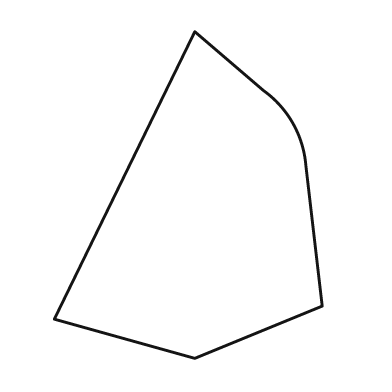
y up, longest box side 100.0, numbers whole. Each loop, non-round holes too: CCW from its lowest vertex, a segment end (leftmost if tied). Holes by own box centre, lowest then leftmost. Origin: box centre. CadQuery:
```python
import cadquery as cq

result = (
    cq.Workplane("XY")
    .moveTo(2.0, -50.0)
    .lineTo(41.0, -34.0)
    .lineTo(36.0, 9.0)
    .threePointArc((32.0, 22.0), (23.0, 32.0))
    .lineTo(2.0, 50.0)
    .lineTo(-41.0, -38.0)
    .close()
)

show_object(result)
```